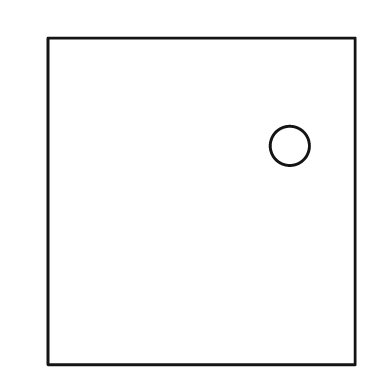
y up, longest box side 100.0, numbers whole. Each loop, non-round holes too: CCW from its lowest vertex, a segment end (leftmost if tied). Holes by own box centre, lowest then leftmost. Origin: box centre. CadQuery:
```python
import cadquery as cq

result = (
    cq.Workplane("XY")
    .moveTo(-47.0, -50.0)
    .lineTo(47.0, -50.0)
    .lineTo(47.0, 50.0)
    .lineTo(-47.0, 50.0)
    .close()
    .moveTo(27.0, 17.0)
    .circle(6.0)
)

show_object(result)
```